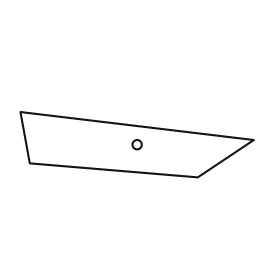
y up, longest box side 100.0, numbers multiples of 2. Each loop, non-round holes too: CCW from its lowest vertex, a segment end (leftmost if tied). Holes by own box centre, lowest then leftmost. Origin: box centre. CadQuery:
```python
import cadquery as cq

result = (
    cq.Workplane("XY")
    .moveTo(26.0, -14.0)
    .lineTo(50.0, 2.0)
    .lineTo(-50.0, 14.0)
    .lineTo(-46.0, -8.0)
    .close()
    .moveTo(0.0, 0.0)
    .circle(2.0)
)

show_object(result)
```